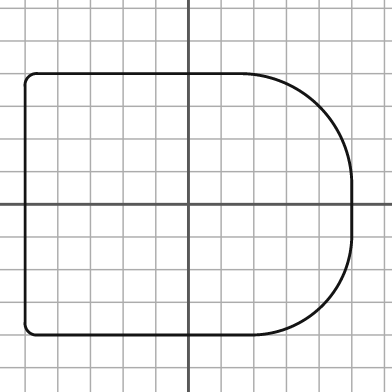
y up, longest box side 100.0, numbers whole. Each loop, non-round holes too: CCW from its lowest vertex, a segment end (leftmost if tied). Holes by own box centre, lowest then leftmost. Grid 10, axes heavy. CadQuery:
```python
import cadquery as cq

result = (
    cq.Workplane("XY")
    .moveTo(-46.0, -40.0)
    .lineTo(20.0, -40.0)
    .threePointArc((41.0, -31.0), (50.0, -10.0))
    .lineTo(50.0, 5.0)
    .threePointArc((40.0, 30.0), (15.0, 40.0))
    .lineTo(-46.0, 40.0)
    .threePointArc((-49.0, 39.0), (-50.0, 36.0))
    .lineTo(-50.0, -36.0)
    .threePointArc((-49.0, -39.0), (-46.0, -40.0))
    .close()
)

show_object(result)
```